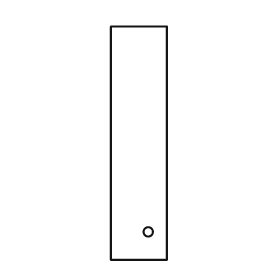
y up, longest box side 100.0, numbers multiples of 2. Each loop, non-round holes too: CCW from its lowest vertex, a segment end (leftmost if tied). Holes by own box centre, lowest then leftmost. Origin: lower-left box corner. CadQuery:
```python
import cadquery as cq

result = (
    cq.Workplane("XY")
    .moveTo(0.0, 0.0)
    .lineTo(24.0, 0.0)
    .lineTo(24.0, 100.0)
    .lineTo(0.0, 100.0)
    .close()
    .moveTo(16.0, 12.0)
    .circle(2.0)
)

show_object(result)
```